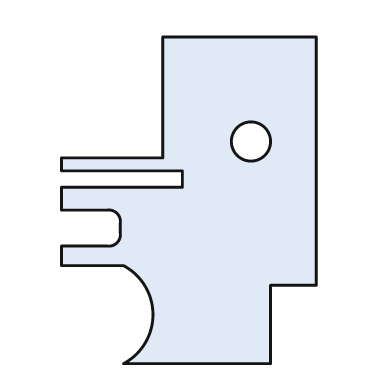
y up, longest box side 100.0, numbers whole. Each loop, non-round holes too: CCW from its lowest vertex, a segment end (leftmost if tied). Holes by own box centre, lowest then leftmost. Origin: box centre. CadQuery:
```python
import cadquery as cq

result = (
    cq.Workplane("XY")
    .moveTo(-20.0, -50.0)
    .lineTo(25.0, -50.0)
    .lineTo(25.0, -26.0)
    .lineTo(39.0, -26.0)
    .lineTo(39.0, 50.0)
    .lineTo(-8.0, 50.0)
    .lineTo(-8.0, 13.0)
    .lineTo(-39.0, 13.0)
    .lineTo(-39.0, 9.0)
    .lineTo(-2.0, 9.0)
    .lineTo(-2.0, 4.0)
    .lineTo(-39.0, 4.0)
    .lineTo(-39.0, -3.0)
    .lineTo(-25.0, -3.0)
    .threePointArc((-22.0, -4.0), (-21.0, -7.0))
    .lineTo(-21.0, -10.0)
    .threePointArc((-22.0, -13.0), (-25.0, -14.0))
    .lineTo(-39.0, -14.0)
    .lineTo(-39.0, -20.0)
    .lineTo(-20.0, -20.0)
    .threePointArc((-11.0, -35.0), (-20.0, -50.0))
    .close()
    .moveTo(19.0, 18.0)
    .circle(6.0)
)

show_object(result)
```